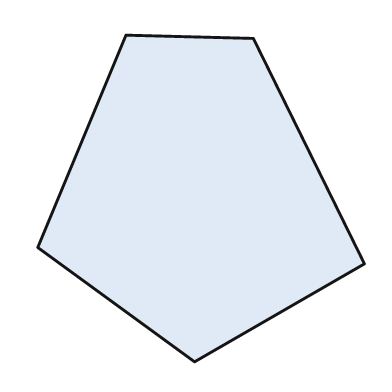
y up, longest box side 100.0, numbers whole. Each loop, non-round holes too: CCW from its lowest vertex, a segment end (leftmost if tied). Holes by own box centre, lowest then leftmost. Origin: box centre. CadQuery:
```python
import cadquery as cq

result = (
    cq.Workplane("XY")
    .moveTo(-2.0, -50.0)
    .lineTo(50.0, -20.0)
    .lineTo(16.0, 49.0)
    .lineTo(-23.0, 50.0)
    .lineTo(-50.0, -15.0)
    .close()
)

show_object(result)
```